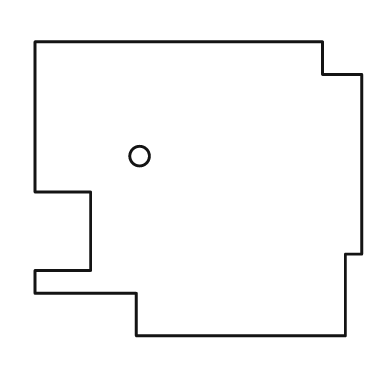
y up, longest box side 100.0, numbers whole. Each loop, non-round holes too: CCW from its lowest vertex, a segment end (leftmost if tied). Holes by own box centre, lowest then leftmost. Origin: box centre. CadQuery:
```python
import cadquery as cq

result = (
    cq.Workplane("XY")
    .moveTo(-19.0, -45.0)
    .lineTo(45.0, -45.0)
    .lineTo(45.0, -20.0)
    .lineTo(50.0, -20.0)
    .lineTo(50.0, 35.0)
    .lineTo(38.0, 35.0)
    .lineTo(38.0, 45.0)
    .lineTo(-50.0, 45.0)
    .lineTo(-50.0, -1.0)
    .lineTo(-33.0, -1.0)
    .lineTo(-33.0, -25.0)
    .lineTo(-50.0, -25.0)
    .lineTo(-50.0, -32.0)
    .lineTo(-19.0, -32.0)
    .close()
    .moveTo(-18.0, 10.0)
    .circle(3.0)
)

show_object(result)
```